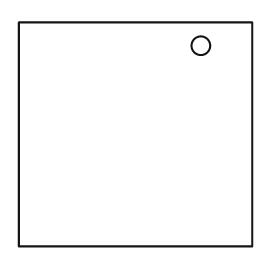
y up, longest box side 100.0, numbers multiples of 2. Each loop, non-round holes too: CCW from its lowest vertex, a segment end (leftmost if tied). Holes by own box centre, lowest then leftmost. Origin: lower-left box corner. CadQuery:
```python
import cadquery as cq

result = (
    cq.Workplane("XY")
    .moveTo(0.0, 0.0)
    .lineTo(100.0, 0.0)
    .lineTo(100.0, 96.0)
    .lineTo(0.0, 96.0)
    .close()
    .moveTo(78.0, 86.0)
    .circle(4.0)
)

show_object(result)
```